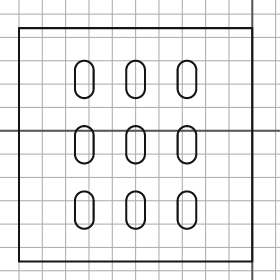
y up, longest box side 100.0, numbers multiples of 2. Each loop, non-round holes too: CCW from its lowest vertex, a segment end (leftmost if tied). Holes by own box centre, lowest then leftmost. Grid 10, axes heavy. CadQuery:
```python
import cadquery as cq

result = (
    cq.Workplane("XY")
    .moveTo(-100.0, -56.0)
    .lineTo(0.0, -56.0)
    .lineTo(0.0, 44.0)
    .lineTo(-100.0, 44.0)
    .close()
    .moveTo(-76.0, -38.0)
    .threePointArc((-72.0, -42.0), (-68.0, -38.0))
    .lineTo(-68.0, -30.0)
    .threePointArc((-72.0, -26.0), (-76.0, -30.0))
    .close()
    .moveTo(-54.0, -38.0)
    .threePointArc((-50.0, -42.0), (-46.0, -38.0))
    .lineTo(-46.0, -30.0)
    .threePointArc((-50.0, -26.0), (-54.0, -30.0))
    .close()
    .moveTo(-32.0, -38.0)
    .threePointArc((-28.0, -42.0), (-24.0, -38.0))
    .lineTo(-24.0, -30.0)
    .threePointArc((-28.0, -26.0), (-32.0, -30.0))
    .close()
    .moveTo(-76.0, -10.0)
    .threePointArc((-72.0, -14.0), (-68.0, -10.0))
    .lineTo(-68.0, -2.0)
    .threePointArc((-72.0, 2.0), (-76.0, -2.0))
    .close()
    .moveTo(-54.0, -10.0)
    .threePointArc((-50.0, -14.0), (-46.0, -10.0))
    .lineTo(-46.0, -2.0)
    .threePointArc((-50.0, 2.0), (-54.0, -2.0))
    .close()
    .moveTo(-32.0, -10.0)
    .threePointArc((-28.0, -14.0), (-24.0, -10.0))
    .lineTo(-24.0, -2.0)
    .threePointArc((-28.0, 2.0), (-32.0, -2.0))
    .close()
    .moveTo(-76.0, 18.0)
    .threePointArc((-72.0, 14.0), (-68.0, 18.0))
    .lineTo(-68.0, 26.0)
    .threePointArc((-72.0, 30.0), (-76.0, 26.0))
    .close()
    .moveTo(-54.0, 18.0)
    .threePointArc((-50.0, 14.0), (-46.0, 18.0))
    .lineTo(-46.0, 26.0)
    .threePointArc((-50.0, 30.0), (-54.0, 26.0))
    .close()
    .moveTo(-32.0, 18.0)
    .threePointArc((-28.0, 14.0), (-24.0, 18.0))
    .lineTo(-24.0, 26.0)
    .threePointArc((-28.0, 30.0), (-32.0, 26.0))
    .close()
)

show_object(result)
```